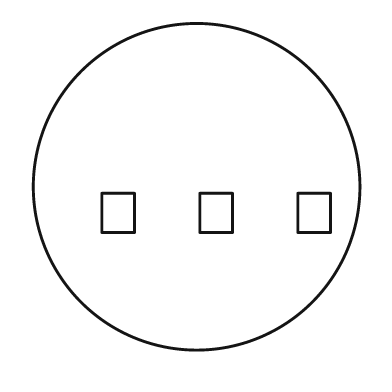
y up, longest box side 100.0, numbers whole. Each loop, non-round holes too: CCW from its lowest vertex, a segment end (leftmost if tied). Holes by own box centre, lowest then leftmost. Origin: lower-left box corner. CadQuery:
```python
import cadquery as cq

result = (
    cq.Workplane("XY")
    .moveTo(50.0, 50.0)
    .circle(50.0)
    .moveTo(21.0, 36.0)
    .lineTo(31.0, 36.0)
    .lineTo(31.0, 48.0)
    .lineTo(21.0, 48.0)
    .close()
    .moveTo(51.0, 36.0)
    .lineTo(61.0, 36.0)
    .lineTo(61.0, 48.0)
    .lineTo(51.0, 48.0)
    .close()
    .moveTo(81.0, 36.0)
    .lineTo(91.0, 36.0)
    .lineTo(91.0, 48.0)
    .lineTo(81.0, 48.0)
    .close()
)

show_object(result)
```